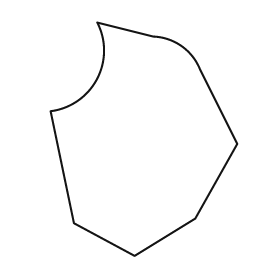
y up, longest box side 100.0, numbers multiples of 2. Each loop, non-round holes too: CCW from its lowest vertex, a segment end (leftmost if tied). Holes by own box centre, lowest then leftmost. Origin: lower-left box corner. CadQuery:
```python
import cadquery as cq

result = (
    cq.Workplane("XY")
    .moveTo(36.0, 0.0)
    .lineTo(62.0, 16.0)
    .lineTo(80.0, 48.0)
    .lineTo(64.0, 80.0)
    .threePointArc((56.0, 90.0), (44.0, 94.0))
    .lineTo(20.0, 100.0)
    .threePointArc((20.0, 76.0), (0.0, 62.0))
    .lineTo(10.0, 14.0)
    .close()
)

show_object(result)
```